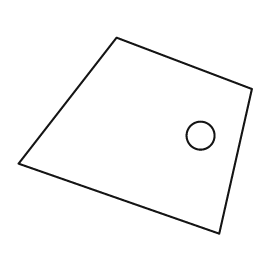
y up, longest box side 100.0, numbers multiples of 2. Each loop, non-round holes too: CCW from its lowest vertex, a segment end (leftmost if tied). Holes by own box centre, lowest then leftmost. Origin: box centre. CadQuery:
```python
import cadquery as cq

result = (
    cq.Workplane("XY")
    .moveTo(36.0, -42.0)
    .lineTo(50.0, 20.0)
    .lineTo(-8.0, 42.0)
    .lineTo(-50.0, -12.0)
    .close()
    .moveTo(28.0, 0.0)
    .circle(6.0)
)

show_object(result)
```